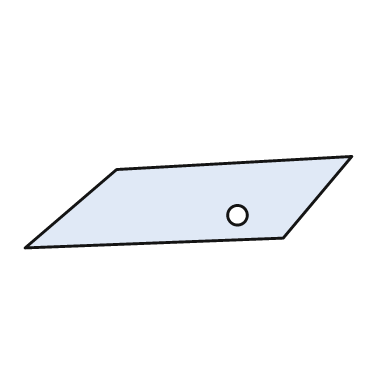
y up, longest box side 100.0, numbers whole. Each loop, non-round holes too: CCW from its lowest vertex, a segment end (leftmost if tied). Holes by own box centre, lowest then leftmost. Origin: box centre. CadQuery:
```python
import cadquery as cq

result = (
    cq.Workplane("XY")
    .moveTo(-50.0, -14.0)
    .lineTo(29.0, -11.0)
    .lineTo(50.0, 14.0)
    .lineTo(-22.0, 10.0)
    .close()
    .moveTo(15.0, -4.0)
    .circle(3.0)
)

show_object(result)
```